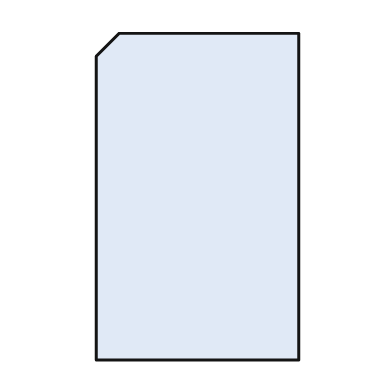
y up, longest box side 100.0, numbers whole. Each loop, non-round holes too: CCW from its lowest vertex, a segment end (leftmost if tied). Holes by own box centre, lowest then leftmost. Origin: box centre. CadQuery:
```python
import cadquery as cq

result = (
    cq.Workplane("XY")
    .moveTo(-31.0, -50.0)
    .lineTo(31.0, -50.0)
    .lineTo(31.0, 50.0)
    .lineTo(-24.0, 50.0)
    .lineTo(-31.0, 43.0)
    .close()
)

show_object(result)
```